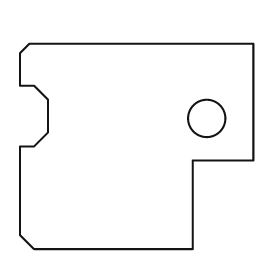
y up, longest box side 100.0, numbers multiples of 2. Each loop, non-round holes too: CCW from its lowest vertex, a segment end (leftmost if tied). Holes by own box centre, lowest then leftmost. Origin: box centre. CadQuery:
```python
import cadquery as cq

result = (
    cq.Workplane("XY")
    .moveTo(-44.0, -44.0)
    .lineTo(24.0, -44.0)
    .lineTo(24.0, -6.0)
    .lineTo(50.0, -6.0)
    .lineTo(50.0, 44.0)
    .lineTo(-46.0, 44.0)
    .lineTo(-50.0, 40.0)
    .lineTo(-50.0, 26.0)
    .lineTo(-44.0, 26.0)
    .lineTo(-38.0, 20.0)
    .lineTo(-38.0, 6.0)
    .lineTo(-44.0, 0.0)
    .lineTo(-50.0, 0.0)
    .lineTo(-50.0, -38.0)
    .close()
    .moveTo(30.0, 12.0)
    .circle(8.0)
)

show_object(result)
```